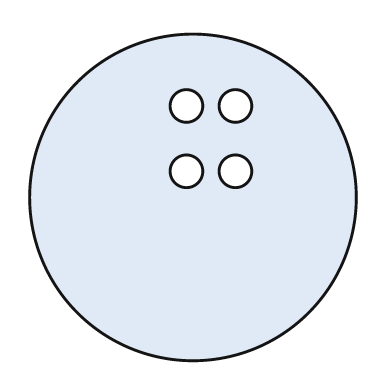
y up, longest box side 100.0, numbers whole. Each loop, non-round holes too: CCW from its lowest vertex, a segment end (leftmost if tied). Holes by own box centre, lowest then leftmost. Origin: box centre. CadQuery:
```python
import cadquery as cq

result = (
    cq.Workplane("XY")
    .moveTo(0.0, 0.0)
    .circle(50.0)
    .moveTo(-2.0, 8.0)
    .circle(5.0)
    .moveTo(13.0, 8.0)
    .circle(5.0)
    .moveTo(-2.0, 28.0)
    .circle(5.0)
    .moveTo(13.0, 28.0)
    .circle(5.0)
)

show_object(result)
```